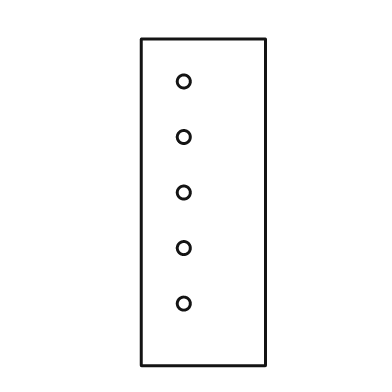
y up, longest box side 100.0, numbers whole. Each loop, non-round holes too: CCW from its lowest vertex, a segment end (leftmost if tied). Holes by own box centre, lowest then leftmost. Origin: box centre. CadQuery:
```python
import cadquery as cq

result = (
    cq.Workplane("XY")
    .moveTo(-19.0, -50.0)
    .lineTo(19.0, -50.0)
    .lineTo(19.0, 50.0)
    .lineTo(-19.0, 50.0)
    .close()
    .moveTo(-6.0, -31.0)
    .circle(2.0)
    .moveTo(-6.0, -14.0)
    .circle(2.0)
    .moveTo(-6.0, 3.0)
    .circle(2.0)
    .moveTo(-6.0, 20.0)
    .circle(2.0)
    .moveTo(-6.0, 37.0)
    .circle(2.0)
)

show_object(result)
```